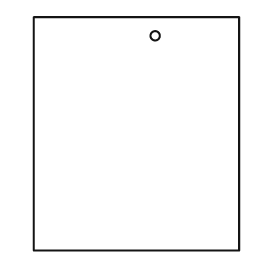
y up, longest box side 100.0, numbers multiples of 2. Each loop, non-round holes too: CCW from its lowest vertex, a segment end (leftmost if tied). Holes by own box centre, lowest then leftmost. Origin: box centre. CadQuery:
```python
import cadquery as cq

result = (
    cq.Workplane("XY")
    .moveTo(-44.0, -50.0)
    .lineTo(44.0, -50.0)
    .lineTo(44.0, 50.0)
    .lineTo(-44.0, 50.0)
    .close()
    .moveTo(8.0, 42.0)
    .circle(2.0)
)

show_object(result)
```